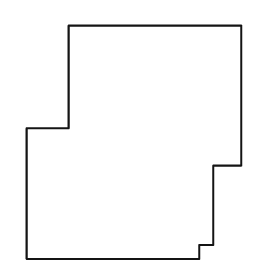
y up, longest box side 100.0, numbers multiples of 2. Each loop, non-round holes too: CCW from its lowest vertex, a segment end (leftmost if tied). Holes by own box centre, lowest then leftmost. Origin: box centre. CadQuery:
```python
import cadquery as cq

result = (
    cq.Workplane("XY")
    .moveTo(-46.0, -50.0)
    .lineTo(28.0, -50.0)
    .lineTo(28.0, -44.0)
    .lineTo(34.0, -44.0)
    .lineTo(34.0, -10.0)
    .lineTo(46.0, -10.0)
    .lineTo(46.0, 50.0)
    .lineTo(-28.0, 50.0)
    .lineTo(-28.0, 6.0)
    .lineTo(-46.0, 6.0)
    .close()
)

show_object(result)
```